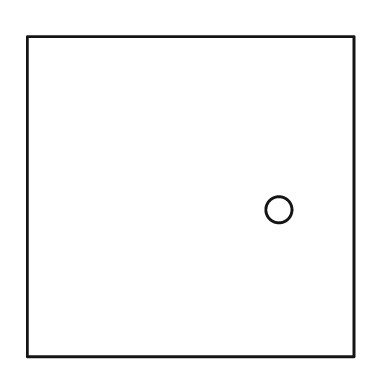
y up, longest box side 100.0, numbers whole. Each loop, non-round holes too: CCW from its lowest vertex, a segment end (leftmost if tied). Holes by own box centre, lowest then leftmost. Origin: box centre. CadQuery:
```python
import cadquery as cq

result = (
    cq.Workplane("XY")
    .moveTo(-50.0, -49.0)
    .lineTo(50.0, -49.0)
    .lineTo(50.0, 49.0)
    .lineTo(-50.0, 49.0)
    .close()
    .moveTo(27.0, -4.0)
    .circle(4.0)
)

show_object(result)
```